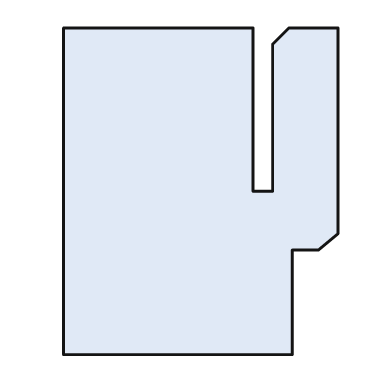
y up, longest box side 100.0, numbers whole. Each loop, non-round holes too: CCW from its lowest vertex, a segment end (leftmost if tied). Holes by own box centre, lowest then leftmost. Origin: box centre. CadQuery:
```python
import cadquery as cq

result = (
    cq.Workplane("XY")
    .moveTo(-42.0, -50.0)
    .lineTo(28.0, -50.0)
    .lineTo(28.0, -18.0)
    .lineTo(36.0, -18.0)
    .lineTo(42.0, -13.0)
    .lineTo(42.0, 50.0)
    .lineTo(27.0, 50.0)
    .lineTo(22.0, 45.0)
    .lineTo(22.0, 0.0)
    .lineTo(16.0, 0.0)
    .lineTo(16.0, 50.0)
    .lineTo(-42.0, 50.0)
    .close()
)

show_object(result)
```